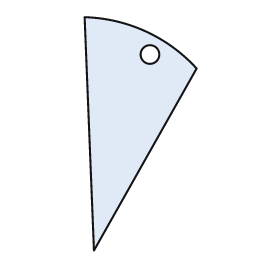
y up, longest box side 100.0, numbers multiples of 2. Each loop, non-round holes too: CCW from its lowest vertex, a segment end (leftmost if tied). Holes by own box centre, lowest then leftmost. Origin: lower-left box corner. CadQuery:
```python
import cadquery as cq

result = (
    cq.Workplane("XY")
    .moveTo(4.0, 0.0)
    .lineTo(48.0, 78.0)
    .threePointArc((26.0, 94.0), (0.0, 100.0))
    .close()
    .moveTo(28.0, 84.0)
    .circle(4.0)
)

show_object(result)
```